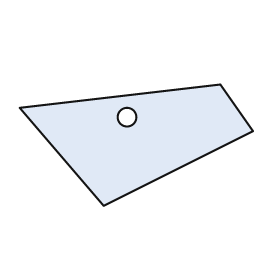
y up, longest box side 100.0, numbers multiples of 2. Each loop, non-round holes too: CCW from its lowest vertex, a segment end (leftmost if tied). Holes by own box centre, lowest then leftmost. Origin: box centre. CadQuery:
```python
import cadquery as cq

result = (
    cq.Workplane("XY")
    .moveTo(-14.0, -26.0)
    .lineTo(50.0, 6.0)
    .lineTo(36.0, 26.0)
    .lineTo(-50.0, 16.0)
    .close()
    .moveTo(-4.0, 12.0)
    .circle(4.0)
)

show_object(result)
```